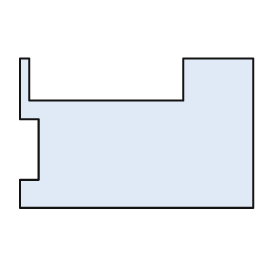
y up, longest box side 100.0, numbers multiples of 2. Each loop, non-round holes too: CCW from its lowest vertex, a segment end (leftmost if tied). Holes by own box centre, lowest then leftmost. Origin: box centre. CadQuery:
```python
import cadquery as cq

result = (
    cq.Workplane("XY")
    .moveTo(-50.0, -32.0)
    .lineTo(50.0, -32.0)
    .lineTo(50.0, 32.0)
    .lineTo(20.0, 32.0)
    .lineTo(20.0, 14.0)
    .lineTo(-46.0, 14.0)
    .lineTo(-46.0, 32.0)
    .lineTo(-50.0, 32.0)
    .lineTo(-50.0, 6.0)
    .lineTo(-42.0, 6.0)
    .lineTo(-42.0, -20.0)
    .lineTo(-50.0, -20.0)
    .close()
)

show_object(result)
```